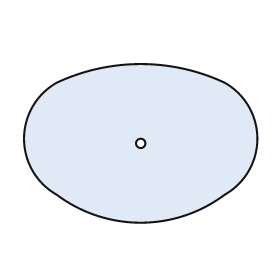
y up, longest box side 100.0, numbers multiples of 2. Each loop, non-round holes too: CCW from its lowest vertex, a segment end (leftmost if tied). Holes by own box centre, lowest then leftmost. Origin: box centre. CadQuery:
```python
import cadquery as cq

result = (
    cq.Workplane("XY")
    .moveTo(-36.0, -22.0)
    .threePointArc((0.0, -34.0), (36.0, -22.0))
    .threePointArc((50.0, 2.0), (36.0, 26.0))
    .threePointArc((0.0, 34.0), (-36.0, 26.0))
    .threePointArc((-50.0, 2.0), (-36.0, -22.0))
    .close()
    .moveTo(0.0, 0.0)
    .circle(2.0)
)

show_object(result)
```